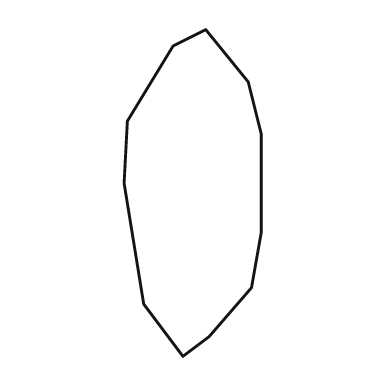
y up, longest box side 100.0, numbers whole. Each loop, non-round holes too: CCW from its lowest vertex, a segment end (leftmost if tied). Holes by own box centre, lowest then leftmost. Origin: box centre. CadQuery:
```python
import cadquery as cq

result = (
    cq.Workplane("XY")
    .moveTo(-3.0, -50.0)
    .lineTo(5.0, -44.0)
    .lineTo(18.0, -29.0)
    .lineTo(21.0, -12.0)
    .lineTo(21.0, 18.0)
    .lineTo(17.0, 34.0)
    .lineTo(4.0, 50.0)
    .lineTo(-6.0, 45.0)
    .lineTo(-20.0, 22.0)
    .lineTo(-21.0, 3.0)
    .lineTo(-15.0, -34.0)
    .close()
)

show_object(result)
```